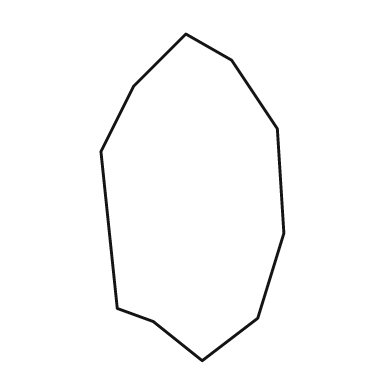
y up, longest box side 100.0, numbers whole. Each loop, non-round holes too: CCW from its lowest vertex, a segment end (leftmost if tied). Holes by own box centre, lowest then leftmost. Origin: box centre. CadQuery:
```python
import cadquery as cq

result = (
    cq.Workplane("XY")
    .moveTo(3.0, -50.0)
    .lineTo(20.0, -37.0)
    .lineTo(28.0, -11.0)
    .lineTo(26.0, 21.0)
    .lineTo(12.0, 42.0)
    .lineTo(-2.0, 50.0)
    .lineTo(-18.0, 34.0)
    .lineTo(-28.0, 14.0)
    .lineTo(-23.0, -34.0)
    .lineTo(-12.0, -38.0)
    .close()
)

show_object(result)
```